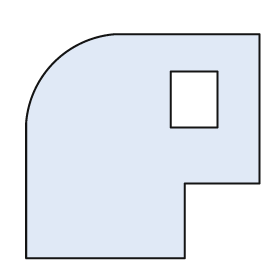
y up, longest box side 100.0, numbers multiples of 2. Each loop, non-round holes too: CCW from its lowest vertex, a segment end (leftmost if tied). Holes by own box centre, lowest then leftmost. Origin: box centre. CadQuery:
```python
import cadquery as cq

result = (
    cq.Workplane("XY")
    .moveTo(-50.0, -48.0)
    .lineTo(18.0, -48.0)
    .lineTo(18.0, -16.0)
    .lineTo(50.0, -16.0)
    .lineTo(50.0, 48.0)
    .lineTo(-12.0, 48.0)
    .threePointArc((-38.0, 36.0), (-50.0, 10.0))
    .close()
    .moveTo(12.0, 8.0)
    .lineTo(32.0, 8.0)
    .lineTo(32.0, 32.0)
    .lineTo(12.0, 32.0)
    .close()
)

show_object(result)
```